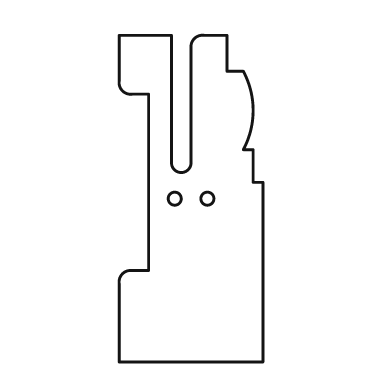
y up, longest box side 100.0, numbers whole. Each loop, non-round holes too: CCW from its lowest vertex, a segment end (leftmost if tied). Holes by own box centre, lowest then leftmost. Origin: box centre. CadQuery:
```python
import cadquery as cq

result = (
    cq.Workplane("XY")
    .moveTo(-22.0, -50.0)
    .lineTo(22.0, -50.0)
    .lineTo(22.0, 5.0)
    .lineTo(19.0, 5.0)
    .lineTo(19.0, 15.0)
    .lineTo(16.0, 15.0)
    .threePointArc((19.0, 27.0), (16.0, 39.0))
    .lineTo(11.0, 39.0)
    .lineTo(11.0, 50.0)
    .lineTo(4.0, 50.0)
    .threePointArc((1.0, 49.0), (0.0, 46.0))
    .lineTo(0.0, 11.0)
    .threePointArc((-3.0, 8.0), (-6.0, 11.0))
    .lineTo(-6.0, 50.0)
    .lineTo(-22.0, 50.0)
    .lineTo(-22.0, 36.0)
    .threePointArc((-21.0, 33.0), (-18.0, 32.0))
    .lineTo(-13.0, 32.0)
    .lineTo(-13.0, -22.0)
    .lineTo(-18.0, -22.0)
    .threePointArc((-21.0, -23.0), (-22.0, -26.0))
    .close()
    .moveTo(-5.0, 0.0)
    .circle(2.0)
    .moveTo(5.0, 0.0)
    .circle(2.0)
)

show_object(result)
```